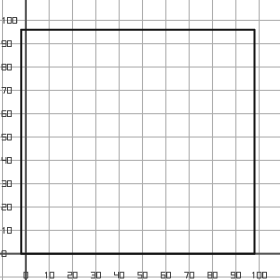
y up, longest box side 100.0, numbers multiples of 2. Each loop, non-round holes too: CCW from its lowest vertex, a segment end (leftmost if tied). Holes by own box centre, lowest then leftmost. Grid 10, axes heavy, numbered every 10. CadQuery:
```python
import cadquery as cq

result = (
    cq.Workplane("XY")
    .moveTo(-2.0, 0.0)
    .lineTo(98.0, 0.0)
    .lineTo(98.0, 96.0)
    .lineTo(-2.0, 96.0)
    .close()
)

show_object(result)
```